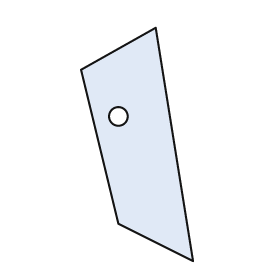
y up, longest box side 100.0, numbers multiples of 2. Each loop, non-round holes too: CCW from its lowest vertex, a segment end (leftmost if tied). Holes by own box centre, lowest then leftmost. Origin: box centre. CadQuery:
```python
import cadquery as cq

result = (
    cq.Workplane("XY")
    .moveTo(24.0, -50.0)
    .lineTo(8.0, 50.0)
    .lineTo(-24.0, 32.0)
    .lineTo(-8.0, -34.0)
    .close()
    .moveTo(-8.0, 12.0)
    .circle(4.0)
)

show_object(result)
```